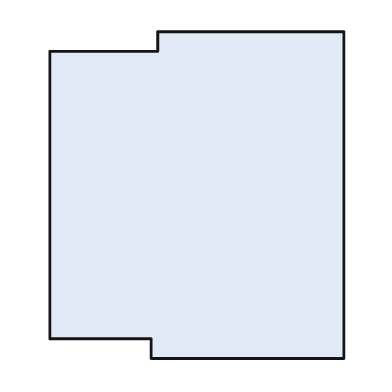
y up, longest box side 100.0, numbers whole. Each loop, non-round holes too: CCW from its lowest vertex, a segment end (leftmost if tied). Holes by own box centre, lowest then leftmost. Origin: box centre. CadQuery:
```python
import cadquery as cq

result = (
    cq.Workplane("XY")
    .moveTo(-14.0, -50.0)
    .lineTo(45.0, -50.0)
    .lineTo(45.0, 50.0)
    .lineTo(-12.0, 50.0)
    .lineTo(-12.0, 44.0)
    .lineTo(-45.0, 44.0)
    .lineTo(-45.0, -44.0)
    .lineTo(-14.0, -44.0)
    .close()
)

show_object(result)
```